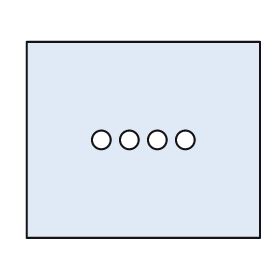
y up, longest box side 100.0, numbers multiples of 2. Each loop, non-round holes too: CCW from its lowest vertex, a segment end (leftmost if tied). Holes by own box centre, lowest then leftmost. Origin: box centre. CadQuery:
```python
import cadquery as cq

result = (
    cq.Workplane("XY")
    .moveTo(-50.0, -42.0)
    .lineTo(50.0, -42.0)
    .lineTo(50.0, 42.0)
    .lineTo(-50.0, 42.0)
    .close()
    .moveTo(-18.0, 0.0)
    .circle(4.0)
    .moveTo(-6.0, 0.0)
    .circle(4.0)
    .moveTo(6.0, 0.0)
    .circle(4.0)
    .moveTo(18.0, 0.0)
    .circle(4.0)
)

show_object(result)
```